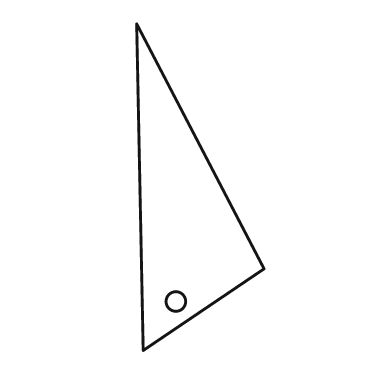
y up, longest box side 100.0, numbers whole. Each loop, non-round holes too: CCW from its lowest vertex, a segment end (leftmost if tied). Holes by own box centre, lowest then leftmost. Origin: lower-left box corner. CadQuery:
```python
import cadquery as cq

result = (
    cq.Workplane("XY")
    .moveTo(2.0, 0.0)
    .lineTo(39.0, 25.0)
    .lineTo(0.0, 100.0)
    .close()
    .moveTo(12.0, 15.0)
    .circle(3.0)
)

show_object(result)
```